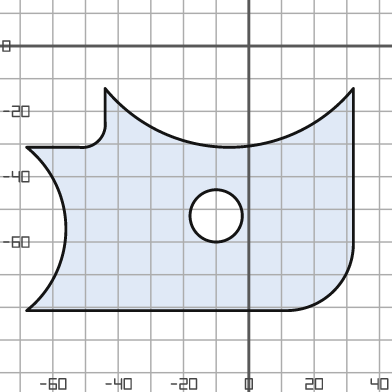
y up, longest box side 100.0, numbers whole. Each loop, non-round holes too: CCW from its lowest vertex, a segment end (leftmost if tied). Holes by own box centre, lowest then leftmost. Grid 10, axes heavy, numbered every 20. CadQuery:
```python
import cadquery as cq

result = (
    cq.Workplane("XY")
    .moveTo(-68.0, -81.0)
    .lineTo(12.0, -81.0)
    .threePointArc((26.0, -75.0), (32.0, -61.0))
    .lineTo(32.0, -13.0)
    .threePointArc((-6.0, -31.0), (-44.0, -13.0))
    .lineTo(-44.0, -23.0)
    .threePointArc((-46.0, -29.0), (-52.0, -31.0))
    .lineTo(-68.0, -31.0)
    .threePointArc((-56.0, -56.0), (-68.0, -81.0))
    .close()
    .moveTo(-10.0, -52.0)
    .circle(8.0)
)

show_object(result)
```